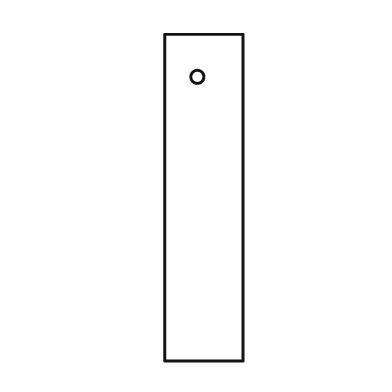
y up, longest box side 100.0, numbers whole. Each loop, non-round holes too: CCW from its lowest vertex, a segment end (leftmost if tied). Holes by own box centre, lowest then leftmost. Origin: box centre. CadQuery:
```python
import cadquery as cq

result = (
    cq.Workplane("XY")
    .moveTo(-12.0, -50.0)
    .lineTo(12.0, -50.0)
    .lineTo(12.0, 50.0)
    .lineTo(-12.0, 50.0)
    .close()
    .moveTo(-2.0, 37.0)
    .circle(2.0)
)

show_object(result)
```